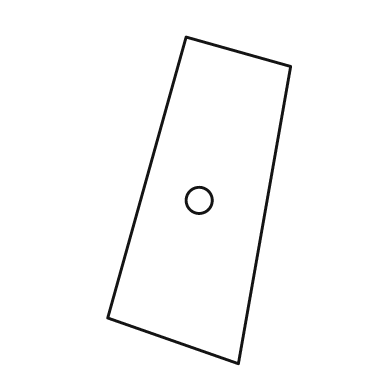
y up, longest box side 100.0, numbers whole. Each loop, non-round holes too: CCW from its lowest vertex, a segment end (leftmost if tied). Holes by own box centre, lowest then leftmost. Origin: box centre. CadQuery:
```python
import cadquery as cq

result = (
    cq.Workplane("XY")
    .moveTo(12.0, -50.0)
    .lineTo(28.0, 41.0)
    .lineTo(-4.0, 50.0)
    .lineTo(-28.0, -36.0)
    .close()
    .moveTo(0.0, 0.0)
    .circle(4.0)
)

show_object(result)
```